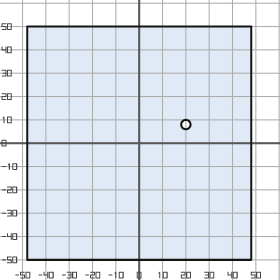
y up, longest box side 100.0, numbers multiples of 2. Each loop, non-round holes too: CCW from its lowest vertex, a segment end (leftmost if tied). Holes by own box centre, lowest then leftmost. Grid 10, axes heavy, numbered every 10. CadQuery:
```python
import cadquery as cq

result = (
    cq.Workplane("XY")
    .moveTo(-48.0, -50.0)
    .lineTo(48.0, -50.0)
    .lineTo(48.0, 50.0)
    .lineTo(-48.0, 50.0)
    .close()
    .moveTo(20.0, 8.0)
    .circle(2.0)
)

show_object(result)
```